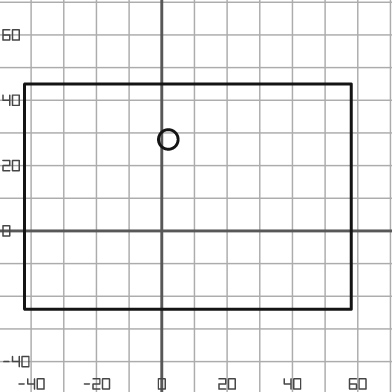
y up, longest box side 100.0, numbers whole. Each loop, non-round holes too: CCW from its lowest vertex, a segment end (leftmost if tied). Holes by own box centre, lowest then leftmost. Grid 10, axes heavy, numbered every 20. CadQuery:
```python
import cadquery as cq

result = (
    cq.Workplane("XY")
    .moveTo(-42.0, -24.0)
    .lineTo(58.0, -24.0)
    .lineTo(58.0, 45.0)
    .lineTo(-42.0, 45.0)
    .close()
    .moveTo(2.0, 28.0)
    .circle(3.0)
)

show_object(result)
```